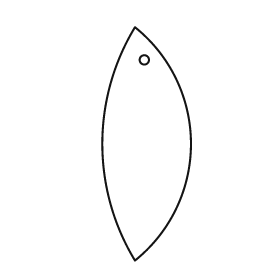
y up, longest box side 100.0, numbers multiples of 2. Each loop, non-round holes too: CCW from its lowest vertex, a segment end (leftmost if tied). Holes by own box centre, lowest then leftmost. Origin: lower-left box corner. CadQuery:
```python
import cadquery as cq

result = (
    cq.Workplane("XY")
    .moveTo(14.0, 0.0)
    .threePointArc((38.0, 50.0), (14.0, 100.0))
    .threePointArc((0.0, 50.0), (14.0, 0.0))
    .close()
    .moveTo(18.0, 86.0)
    .circle(2.0)
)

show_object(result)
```